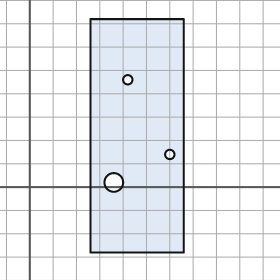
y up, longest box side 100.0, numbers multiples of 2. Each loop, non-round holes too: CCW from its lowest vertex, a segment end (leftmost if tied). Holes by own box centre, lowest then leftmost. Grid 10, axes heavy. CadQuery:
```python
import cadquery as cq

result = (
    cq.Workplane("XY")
    .moveTo(26.0, -28.0)
    .lineTo(66.0, -28.0)
    .lineTo(66.0, 72.0)
    .lineTo(26.0, 72.0)
    .close()
    .moveTo(36.0, 2.0)
    .circle(4.0)
    .moveTo(60.0, 14.0)
    .circle(2.0)
    .moveTo(42.0, 46.0)
    .circle(2.0)
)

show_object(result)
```